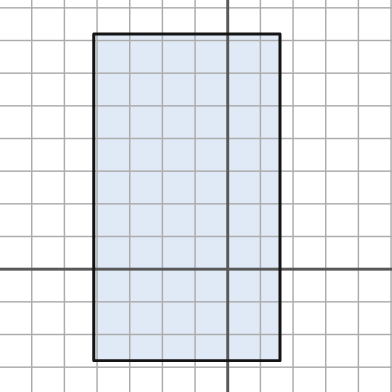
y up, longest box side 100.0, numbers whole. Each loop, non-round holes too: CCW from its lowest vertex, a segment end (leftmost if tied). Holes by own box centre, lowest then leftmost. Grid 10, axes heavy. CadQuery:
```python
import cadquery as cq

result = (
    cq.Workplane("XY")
    .moveTo(-41.0, -28.0)
    .lineTo(16.0, -28.0)
    .lineTo(16.0, 72.0)
    .lineTo(-41.0, 72.0)
    .close()
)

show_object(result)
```